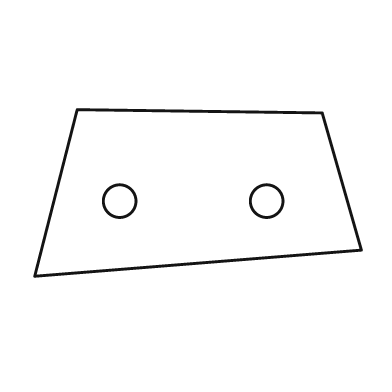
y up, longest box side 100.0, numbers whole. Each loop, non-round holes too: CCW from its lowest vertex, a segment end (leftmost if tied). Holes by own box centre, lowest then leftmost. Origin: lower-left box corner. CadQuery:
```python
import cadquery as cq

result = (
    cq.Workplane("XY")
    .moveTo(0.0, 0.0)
    .lineTo(100.0, 8.0)
    .lineTo(88.0, 50.0)
    .lineTo(13.0, 51.0)
    .close()
    .moveTo(26.0, 23.0)
    .circle(5.0)
    .moveTo(71.0, 23.0)
    .circle(5.0)
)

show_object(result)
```